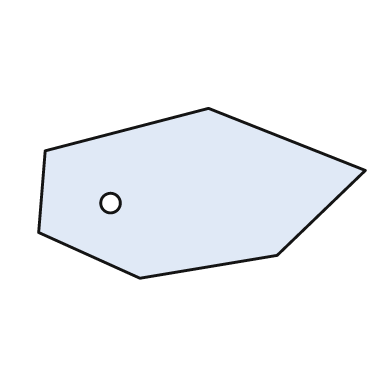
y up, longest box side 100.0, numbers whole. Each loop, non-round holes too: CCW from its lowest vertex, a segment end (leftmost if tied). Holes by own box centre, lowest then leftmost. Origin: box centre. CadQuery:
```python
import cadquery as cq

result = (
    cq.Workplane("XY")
    .moveTo(-19.0, -26.0)
    .lineTo(23.0, -19.0)
    .lineTo(50.0, 7.0)
    .lineTo(2.0, 26.0)
    .lineTo(-48.0, 13.0)
    .lineTo(-50.0, -12.0)
    .close()
    .moveTo(-28.0, -3.0)
    .circle(3.0)
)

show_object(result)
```